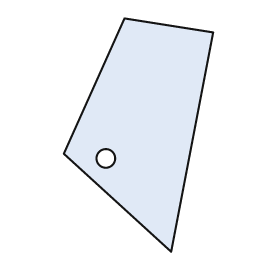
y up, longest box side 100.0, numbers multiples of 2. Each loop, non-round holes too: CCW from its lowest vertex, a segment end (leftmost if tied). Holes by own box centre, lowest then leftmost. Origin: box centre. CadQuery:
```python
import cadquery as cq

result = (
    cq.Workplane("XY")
    .moveTo(14.0, -50.0)
    .lineTo(32.0, 44.0)
    .lineTo(-6.0, 50.0)
    .lineTo(-32.0, -8.0)
    .close()
    .moveTo(-14.0, -10.0)
    .circle(4.0)
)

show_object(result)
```